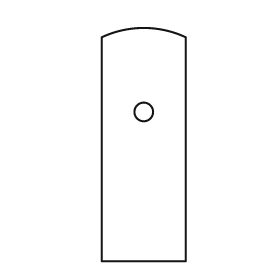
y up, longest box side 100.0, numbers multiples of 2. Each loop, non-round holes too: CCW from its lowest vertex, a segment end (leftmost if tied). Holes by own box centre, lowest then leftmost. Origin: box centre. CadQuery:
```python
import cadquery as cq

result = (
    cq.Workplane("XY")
    .moveTo(-18.0, -50.0)
    .lineTo(18.0, -50.0)
    .lineTo(18.0, 46.0)
    .threePointArc((0.0, 50.0), (-18.0, 46.0))
    .close()
    .moveTo(0.0, 14.0)
    .circle(4.0)
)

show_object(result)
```